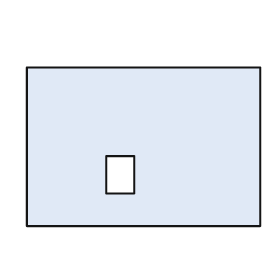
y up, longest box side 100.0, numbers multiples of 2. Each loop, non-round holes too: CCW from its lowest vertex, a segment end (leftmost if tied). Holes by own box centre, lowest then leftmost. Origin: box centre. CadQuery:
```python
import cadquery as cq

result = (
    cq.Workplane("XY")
    .moveTo(-50.0, -34.0)
    .lineTo(50.0, -34.0)
    .lineTo(50.0, 34.0)
    .lineTo(-50.0, 34.0)
    .close()
    .moveTo(-16.0, -20.0)
    .lineTo(-4.0, -20.0)
    .lineTo(-4.0, -4.0)
    .lineTo(-16.0, -4.0)
    .close()
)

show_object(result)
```